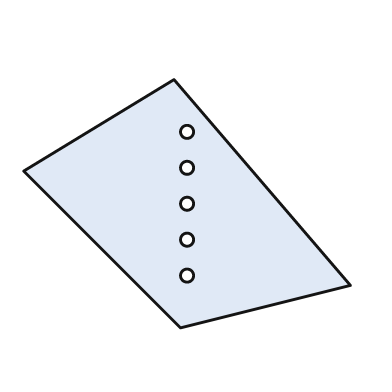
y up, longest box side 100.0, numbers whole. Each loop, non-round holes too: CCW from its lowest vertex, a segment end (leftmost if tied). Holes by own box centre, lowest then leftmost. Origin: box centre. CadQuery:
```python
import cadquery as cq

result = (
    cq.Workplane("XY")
    .moveTo(-2.0, -38.0)
    .lineTo(50.0, -25.0)
    .lineTo(-4.0, 38.0)
    .lineTo(-50.0, 10.0)
    .close()
    .moveTo(0.0, -22.0)
    .circle(2.0)
    .moveTo(0.0, -11.0)
    .circle(2.0)
    .moveTo(0.0, 0.0)
    .circle(2.0)
    .moveTo(0.0, 11.0)
    .circle(2.0)
    .moveTo(0.0, 22.0)
    .circle(2.0)
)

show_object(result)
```